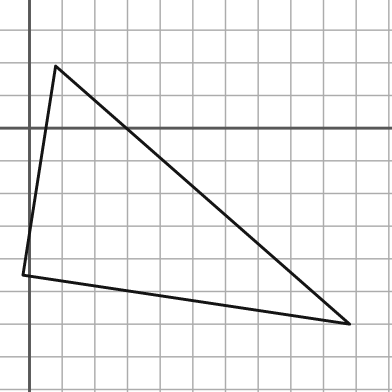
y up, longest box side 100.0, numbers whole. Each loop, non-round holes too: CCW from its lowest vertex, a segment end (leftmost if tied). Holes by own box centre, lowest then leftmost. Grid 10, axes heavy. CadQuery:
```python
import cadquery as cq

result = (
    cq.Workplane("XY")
    .moveTo(98.0, -60.0)
    .lineTo(8.0, 19.0)
    .lineTo(-2.0, -45.0)
    .close()
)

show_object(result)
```